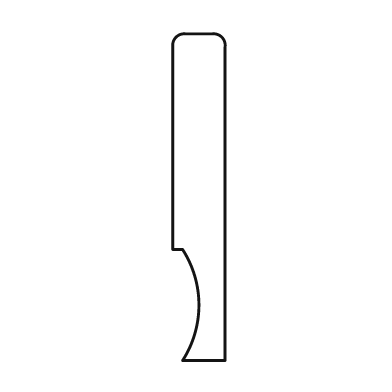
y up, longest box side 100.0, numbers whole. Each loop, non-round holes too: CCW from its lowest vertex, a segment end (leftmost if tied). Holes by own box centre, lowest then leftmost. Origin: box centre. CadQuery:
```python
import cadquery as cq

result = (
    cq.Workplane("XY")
    .moveTo(-5.0, -50.0)
    .lineTo(8.0, -50.0)
    .lineTo(8.0, 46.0)
    .threePointArc((7.0, 49.0), (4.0, 50.0))
    .lineTo(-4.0, 50.0)
    .threePointArc((-7.0, 49.0), (-8.0, 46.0))
    .lineTo(-8.0, -16.0)
    .lineTo(-5.0, -16.0)
    .threePointArc((0.0, -33.0), (-5.0, -50.0))
    .close()
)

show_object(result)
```